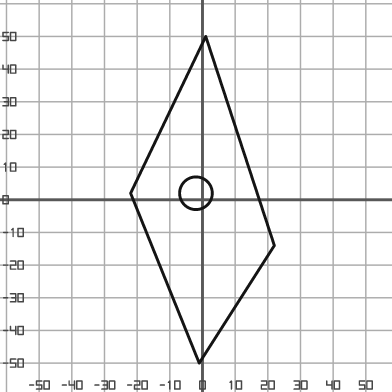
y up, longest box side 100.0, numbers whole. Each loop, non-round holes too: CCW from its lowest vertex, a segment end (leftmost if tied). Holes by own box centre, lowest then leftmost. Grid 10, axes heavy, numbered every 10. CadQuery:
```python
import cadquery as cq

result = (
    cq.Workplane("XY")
    .moveTo(-1.0, -50.0)
    .lineTo(22.0, -14.0)
    .lineTo(1.0, 50.0)
    .lineTo(-22.0, 2.0)
    .close()
    .moveTo(-2.0, 2.0)
    .circle(5.0)
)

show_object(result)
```